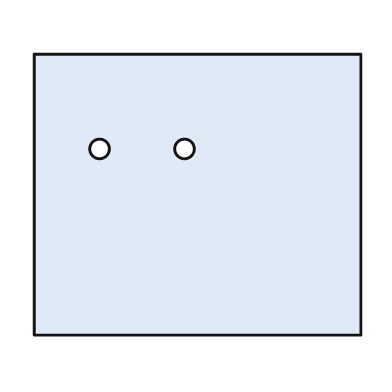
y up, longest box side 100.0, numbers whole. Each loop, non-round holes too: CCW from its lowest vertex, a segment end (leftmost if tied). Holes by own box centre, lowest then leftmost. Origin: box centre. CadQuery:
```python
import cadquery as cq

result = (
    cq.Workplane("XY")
    .moveTo(-50.0, -43.0)
    .lineTo(50.0, -43.0)
    .lineTo(50.0, 43.0)
    .lineTo(-50.0, 43.0)
    .close()
    .moveTo(-30.0, 14.0)
    .circle(3.0)
    .moveTo(-4.0, 14.0)
    .circle(3.0)
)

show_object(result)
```